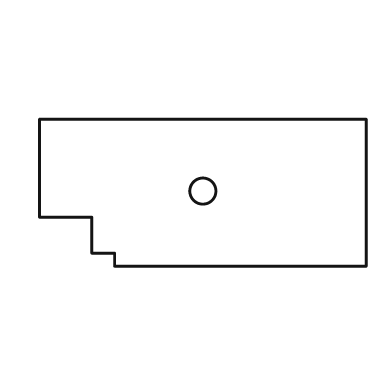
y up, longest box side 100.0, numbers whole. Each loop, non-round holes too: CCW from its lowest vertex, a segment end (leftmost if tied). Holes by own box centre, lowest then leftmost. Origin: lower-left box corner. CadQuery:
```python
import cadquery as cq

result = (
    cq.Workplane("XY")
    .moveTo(23.0, 0.0)
    .lineTo(100.0, 0.0)
    .lineTo(100.0, 45.0)
    .lineTo(0.0, 45.0)
    .lineTo(0.0, 15.0)
    .lineTo(16.0, 15.0)
    .lineTo(16.0, 4.0)
    .lineTo(23.0, 4.0)
    .close()
    .moveTo(50.0, 23.0)
    .circle(4.0)
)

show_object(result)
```